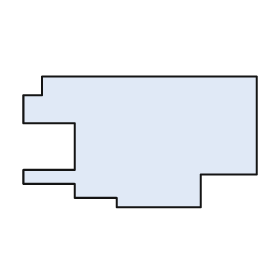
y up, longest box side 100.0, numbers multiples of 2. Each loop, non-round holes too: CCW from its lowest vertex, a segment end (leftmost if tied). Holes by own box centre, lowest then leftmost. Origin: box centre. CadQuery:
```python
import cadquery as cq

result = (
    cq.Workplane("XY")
    .moveTo(-10.0, -28.0)
    .lineTo(26.0, -28.0)
    .lineTo(26.0, -14.0)
    .lineTo(50.0, -14.0)
    .lineTo(50.0, 28.0)
    .lineTo(-42.0, 28.0)
    .lineTo(-42.0, 20.0)
    .lineTo(-50.0, 20.0)
    .lineTo(-50.0, 8.0)
    .lineTo(-28.0, 8.0)
    .lineTo(-28.0, -12.0)
    .lineTo(-50.0, -12.0)
    .lineTo(-50.0, -18.0)
    .lineTo(-28.0, -18.0)
    .lineTo(-28.0, -24.0)
    .lineTo(-10.0, -24.0)
    .close()
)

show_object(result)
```